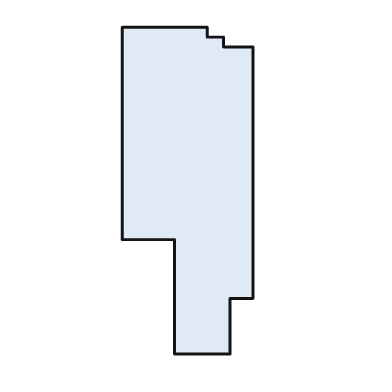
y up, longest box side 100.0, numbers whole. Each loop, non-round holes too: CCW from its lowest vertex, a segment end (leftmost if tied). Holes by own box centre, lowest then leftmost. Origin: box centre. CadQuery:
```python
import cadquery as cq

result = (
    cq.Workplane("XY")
    .moveTo(-4.0, -50.0)
    .lineTo(13.0, -50.0)
    .lineTo(13.0, -33.0)
    .lineTo(20.0, -33.0)
    .lineTo(20.0, 44.0)
    .lineTo(11.0, 44.0)
    .lineTo(11.0, 47.0)
    .lineTo(6.0, 47.0)
    .lineTo(6.0, 50.0)
    .lineTo(-20.0, 50.0)
    .lineTo(-20.0, -15.0)
    .lineTo(-4.0, -15.0)
    .close()
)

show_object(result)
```